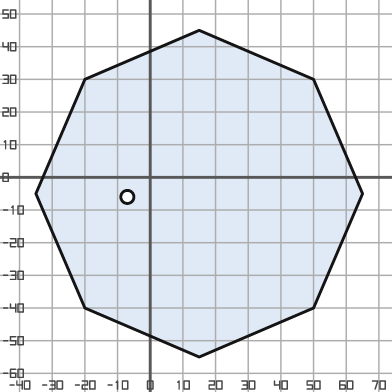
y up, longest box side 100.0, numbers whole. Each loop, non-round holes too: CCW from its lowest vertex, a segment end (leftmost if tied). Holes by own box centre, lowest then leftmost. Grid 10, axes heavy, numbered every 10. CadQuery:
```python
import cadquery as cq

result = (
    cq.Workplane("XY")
    .moveTo(15.0, -55.0)
    .lineTo(50.0, -40.0)
    .lineTo(65.0, -5.0)
    .lineTo(50.0, 30.0)
    .lineTo(15.0, 45.0)
    .lineTo(-20.0, 30.0)
    .lineTo(-35.0, -5.0)
    .lineTo(-20.0, -40.0)
    .close()
    .moveTo(-7.0, -6.0)
    .circle(2.0)
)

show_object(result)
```